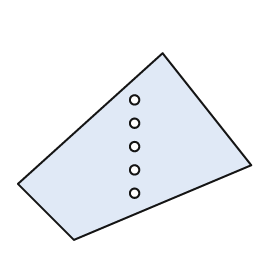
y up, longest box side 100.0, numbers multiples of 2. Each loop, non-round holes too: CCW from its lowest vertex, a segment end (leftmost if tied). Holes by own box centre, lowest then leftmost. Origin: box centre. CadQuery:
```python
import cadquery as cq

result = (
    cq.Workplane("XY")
    .moveTo(-26.0, -40.0)
    .lineTo(50.0, -8.0)
    .lineTo(12.0, 40.0)
    .lineTo(-50.0, -16.0)
    .close()
    .moveTo(0.0, -20.0)
    .circle(2.0)
    .moveTo(0.0, -10.0)
    .circle(2.0)
    .moveTo(0.0, 0.0)
    .circle(2.0)
    .moveTo(0.0, 10.0)
    .circle(2.0)
    .moveTo(0.0, 20.0)
    .circle(2.0)
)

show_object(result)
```